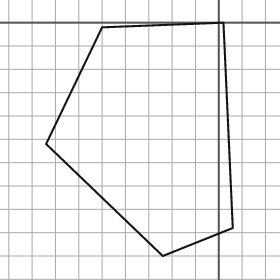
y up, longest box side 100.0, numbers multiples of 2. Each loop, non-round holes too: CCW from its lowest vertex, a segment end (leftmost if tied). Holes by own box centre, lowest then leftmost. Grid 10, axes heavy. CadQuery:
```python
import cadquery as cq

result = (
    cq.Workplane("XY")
    .moveTo(-24.0, -100.0)
    .lineTo(6.0, -88.0)
    .lineTo(2.0, 0.0)
    .lineTo(-50.0, -2.0)
    .lineTo(-74.0, -52.0)
    .close()
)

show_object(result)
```